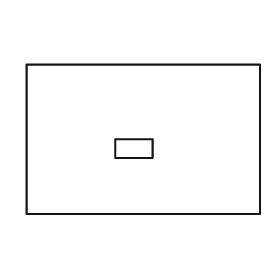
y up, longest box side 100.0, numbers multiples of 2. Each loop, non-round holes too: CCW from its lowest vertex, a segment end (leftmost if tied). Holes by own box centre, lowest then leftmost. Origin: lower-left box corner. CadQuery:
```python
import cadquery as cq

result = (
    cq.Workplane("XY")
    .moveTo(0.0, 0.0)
    .lineTo(100.0, 0.0)
    .lineTo(100.0, 64.0)
    .lineTo(0.0, 64.0)
    .close()
    .moveTo(38.0, 24.0)
    .lineTo(54.0, 24.0)
    .lineTo(54.0, 32.0)
    .lineTo(38.0, 32.0)
    .close()
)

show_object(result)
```